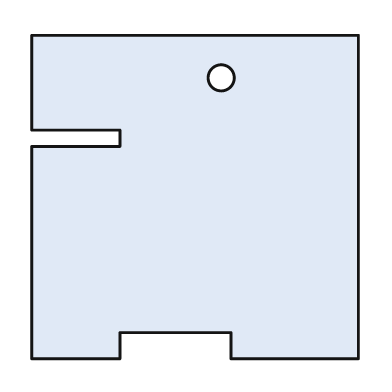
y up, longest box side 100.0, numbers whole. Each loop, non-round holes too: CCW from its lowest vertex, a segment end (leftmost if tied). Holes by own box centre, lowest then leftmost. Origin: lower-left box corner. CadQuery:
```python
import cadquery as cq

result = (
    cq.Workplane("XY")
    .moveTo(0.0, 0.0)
    .lineTo(27.0, 0.0)
    .lineTo(27.0, 8.0)
    .lineTo(61.0, 8.0)
    .lineTo(61.0, 0.0)
    .lineTo(100.0, 0.0)
    .lineTo(100.0, 99.0)
    .lineTo(0.0, 99.0)
    .lineTo(0.0, 70.0)
    .lineTo(27.0, 70.0)
    .lineTo(27.0, 65.0)
    .lineTo(0.0, 65.0)
    .close()
    .moveTo(58.0, 86.0)
    .circle(4.0)
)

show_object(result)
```